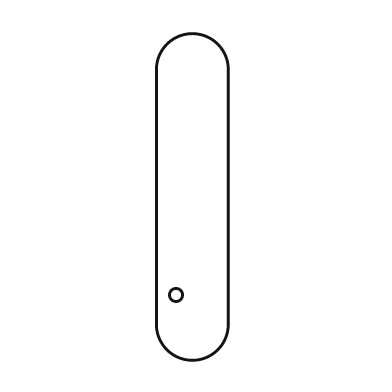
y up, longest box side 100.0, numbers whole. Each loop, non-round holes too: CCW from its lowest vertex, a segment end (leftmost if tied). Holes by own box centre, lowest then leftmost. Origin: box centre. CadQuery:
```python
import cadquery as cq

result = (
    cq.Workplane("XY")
    .moveTo(-11.0, -39.0)
    .threePointArc((0.0, -50.0), (11.0, -39.0))
    .lineTo(11.0, 39.0)
    .threePointArc((0.0, 50.0), (-11.0, 39.0))
    .close()
    .moveTo(-5.0, -30.0)
    .circle(2.0)
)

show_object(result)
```